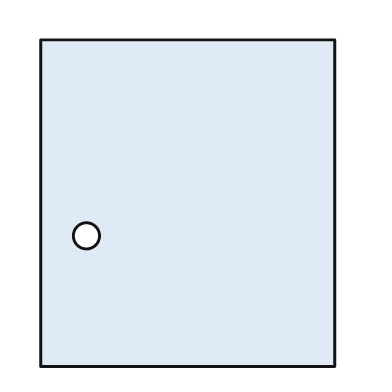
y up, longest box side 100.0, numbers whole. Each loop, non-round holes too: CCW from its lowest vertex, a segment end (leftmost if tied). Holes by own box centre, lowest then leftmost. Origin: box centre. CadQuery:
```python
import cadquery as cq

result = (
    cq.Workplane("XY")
    .moveTo(-45.0, -50.0)
    .lineTo(45.0, -50.0)
    .lineTo(45.0, 50.0)
    .lineTo(-45.0, 50.0)
    .close()
    .moveTo(-31.0, -10.0)
    .circle(4.0)
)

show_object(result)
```